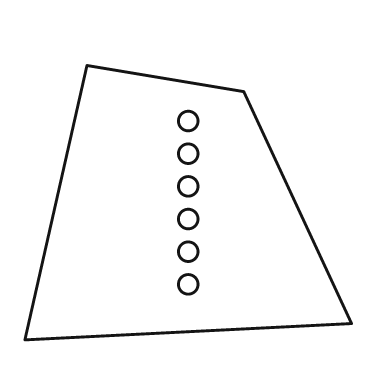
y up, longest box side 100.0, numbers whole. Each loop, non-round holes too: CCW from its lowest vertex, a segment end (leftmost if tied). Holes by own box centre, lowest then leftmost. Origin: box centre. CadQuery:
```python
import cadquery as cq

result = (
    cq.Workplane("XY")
    .moveTo(-50.0, -42.0)
    .lineTo(50.0, -37.0)
    .lineTo(17.0, 34.0)
    .lineTo(-31.0, 42.0)
    .close()
    .moveTo(0.0, -25.0)
    .circle(3.0)
    .moveTo(0.0, -15.0)
    .circle(3.0)
    .moveTo(0.0, -5.0)
    .circle(3.0)
    .moveTo(0.0, 5.0)
    .circle(3.0)
    .moveTo(0.0, 15.0)
    .circle(3.0)
    .moveTo(0.0, 25.0)
    .circle(3.0)
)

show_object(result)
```